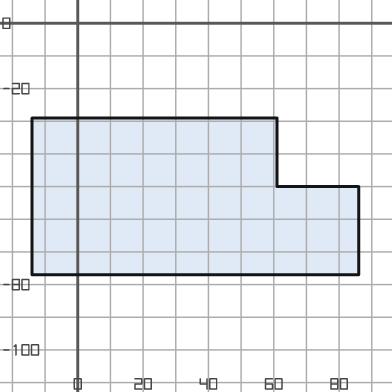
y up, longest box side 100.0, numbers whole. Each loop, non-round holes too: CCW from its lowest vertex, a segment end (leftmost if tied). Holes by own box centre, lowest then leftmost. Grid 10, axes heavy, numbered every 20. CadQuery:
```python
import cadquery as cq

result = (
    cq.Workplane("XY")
    .moveTo(-14.0, -77.0)
    .lineTo(86.0, -77.0)
    .lineTo(86.0, -50.0)
    .lineTo(61.0, -50.0)
    .lineTo(61.0, -29.0)
    .lineTo(-14.0, -29.0)
    .close()
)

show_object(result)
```